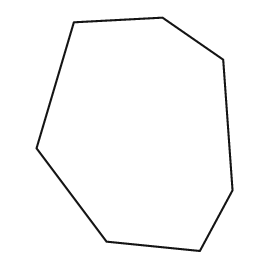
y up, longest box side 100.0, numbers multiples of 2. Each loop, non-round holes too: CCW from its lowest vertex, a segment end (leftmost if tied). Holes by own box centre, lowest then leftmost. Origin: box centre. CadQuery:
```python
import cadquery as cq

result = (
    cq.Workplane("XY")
    .moveTo(28.0, -50.0)
    .lineTo(42.0, -24.0)
    .lineTo(38.0, 32.0)
    .lineTo(12.0, 50.0)
    .lineTo(-26.0, 48.0)
    .lineTo(-42.0, -6.0)
    .lineTo(-12.0, -46.0)
    .close()
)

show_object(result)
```